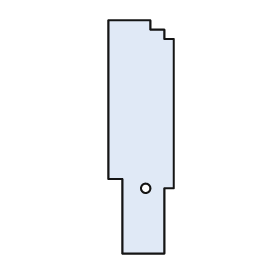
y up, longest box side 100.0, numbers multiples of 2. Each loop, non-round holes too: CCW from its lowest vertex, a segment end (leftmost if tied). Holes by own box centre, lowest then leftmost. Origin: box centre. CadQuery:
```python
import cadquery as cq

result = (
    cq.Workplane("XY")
    .moveTo(-8.0, -50.0)
    .lineTo(10.0, -50.0)
    .lineTo(10.0, -22.0)
    .lineTo(14.0, -22.0)
    .lineTo(14.0, 42.0)
    .lineTo(10.0, 42.0)
    .lineTo(10.0, 46.0)
    .lineTo(4.0, 46.0)
    .lineTo(4.0, 50.0)
    .lineTo(-14.0, 50.0)
    .lineTo(-14.0, -18.0)
    .lineTo(-8.0, -18.0)
    .close()
    .moveTo(2.0, -22.0)
    .circle(2.0)
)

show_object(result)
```